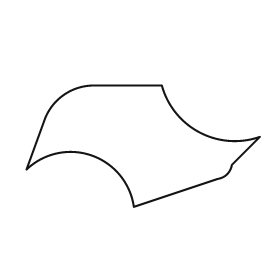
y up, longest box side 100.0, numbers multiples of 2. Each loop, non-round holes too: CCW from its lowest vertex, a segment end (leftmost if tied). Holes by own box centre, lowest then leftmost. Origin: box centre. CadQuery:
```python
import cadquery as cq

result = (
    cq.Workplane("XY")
    .moveTo(-4.0, -26.0)
    .lineTo(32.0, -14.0)
    .threePointArc((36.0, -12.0), (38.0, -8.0))
    .lineTo(50.0, 4.0)
    .threePointArc((24.0, 6.0), (8.0, 26.0))
    .lineTo(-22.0, 26.0)
    .threePointArc((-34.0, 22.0), (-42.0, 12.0))
    .lineTo(-50.0, -10.0)
    .threePointArc((-22.0, -4.0), (-4.0, -26.0))
    .close()
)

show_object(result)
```